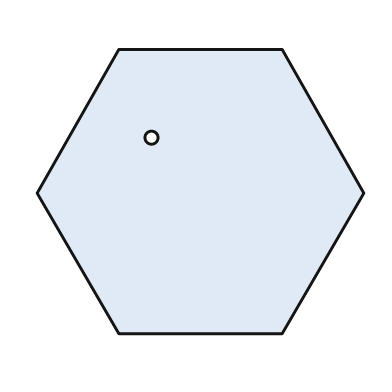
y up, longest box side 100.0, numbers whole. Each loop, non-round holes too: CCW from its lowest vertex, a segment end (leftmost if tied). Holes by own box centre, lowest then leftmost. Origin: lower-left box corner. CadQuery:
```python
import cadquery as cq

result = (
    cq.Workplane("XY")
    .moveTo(25.0, 0.0)
    .lineTo(75.0, 0.0)
    .lineTo(100.0, 43.0)
    .lineTo(75.0, 87.0)
    .lineTo(25.0, 87.0)
    .lineTo(0.0, 43.0)
    .close()
    .moveTo(35.0, 60.0)
    .circle(2.0)
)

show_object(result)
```